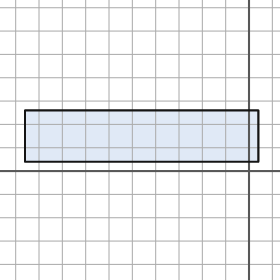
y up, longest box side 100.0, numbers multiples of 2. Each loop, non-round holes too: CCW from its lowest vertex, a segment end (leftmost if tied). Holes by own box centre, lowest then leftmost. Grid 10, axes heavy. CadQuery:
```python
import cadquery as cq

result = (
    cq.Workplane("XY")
    .moveTo(-96.0, 4.0)
    .lineTo(4.0, 4.0)
    .lineTo(4.0, 26.0)
    .lineTo(-96.0, 26.0)
    .close()
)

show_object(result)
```